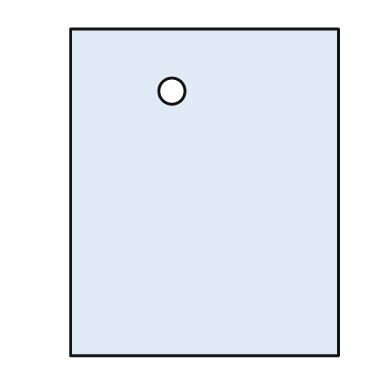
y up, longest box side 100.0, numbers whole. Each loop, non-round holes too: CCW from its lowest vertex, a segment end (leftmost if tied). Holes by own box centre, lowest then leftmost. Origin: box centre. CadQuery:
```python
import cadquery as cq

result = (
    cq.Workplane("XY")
    .moveTo(-41.0, -50.0)
    .lineTo(41.0, -50.0)
    .lineTo(41.0, 50.0)
    .lineTo(-41.0, 50.0)
    .close()
    .moveTo(-10.0, 31.0)
    .circle(4.0)
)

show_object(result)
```